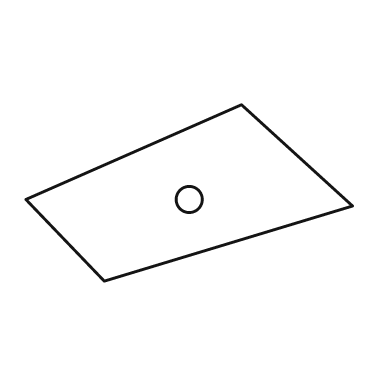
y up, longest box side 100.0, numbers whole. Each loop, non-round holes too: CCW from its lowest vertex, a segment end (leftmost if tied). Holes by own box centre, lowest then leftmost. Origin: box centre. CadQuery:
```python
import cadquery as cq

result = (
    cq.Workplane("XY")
    .moveTo(-26.0, -27.0)
    .lineTo(50.0, -4.0)
    .lineTo(16.0, 27.0)
    .lineTo(-50.0, -2.0)
    .close()
    .moveTo(0.0, -2.0)
    .circle(4.0)
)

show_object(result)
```